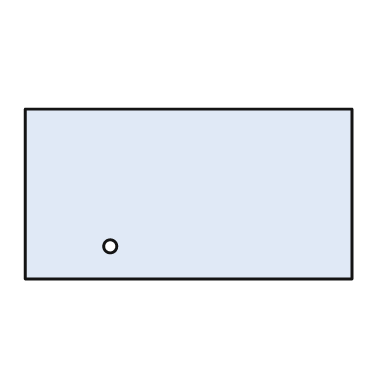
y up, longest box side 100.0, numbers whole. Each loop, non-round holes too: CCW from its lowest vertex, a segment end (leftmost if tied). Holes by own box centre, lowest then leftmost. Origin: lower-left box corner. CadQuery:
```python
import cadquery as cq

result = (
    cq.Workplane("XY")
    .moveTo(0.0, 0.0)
    .lineTo(100.0, 0.0)
    .lineTo(100.0, 52.0)
    .lineTo(0.0, 52.0)
    .close()
    .moveTo(26.0, 10.0)
    .circle(2.0)
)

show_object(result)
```